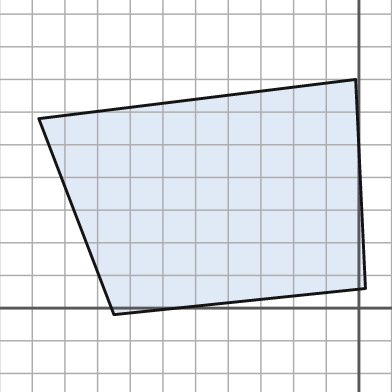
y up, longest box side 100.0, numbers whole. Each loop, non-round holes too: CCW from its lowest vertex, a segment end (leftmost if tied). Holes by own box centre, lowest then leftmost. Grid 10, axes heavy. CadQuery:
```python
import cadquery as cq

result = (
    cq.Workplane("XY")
    .moveTo(-75.0, -2.0)
    .lineTo(2.0, 6.0)
    .lineTo(-1.0, 70.0)
    .lineTo(-98.0, 58.0)
    .close()
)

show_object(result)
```